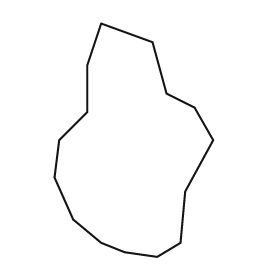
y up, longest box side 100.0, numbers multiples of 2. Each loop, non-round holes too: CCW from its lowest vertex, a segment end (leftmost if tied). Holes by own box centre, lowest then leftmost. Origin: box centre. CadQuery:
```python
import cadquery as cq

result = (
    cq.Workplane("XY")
    .moveTo(10.0, -50.0)
    .lineTo(20.0, -44.0)
    .lineTo(22.0, -22.0)
    .lineTo(34.0, 0.0)
    .lineTo(26.0, 14.0)
    .lineTo(14.0, 20.0)
    .lineTo(8.0, 42.0)
    .lineTo(-14.0, 50.0)
    .lineTo(-20.0, 32.0)
    .lineTo(-20.0, 12.0)
    .lineTo(-32.0, 0.0)
    .lineTo(-34.0, -16.0)
    .lineTo(-26.0, -34.0)
    .lineTo(-14.0, -44.0)
    .lineTo(-4.0, -48.0)
    .close()
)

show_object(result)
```